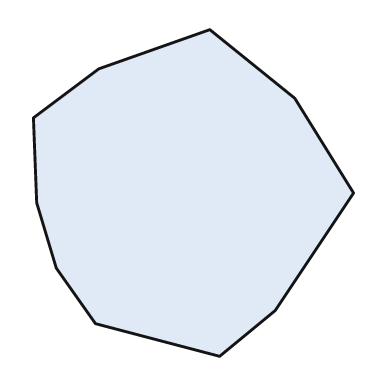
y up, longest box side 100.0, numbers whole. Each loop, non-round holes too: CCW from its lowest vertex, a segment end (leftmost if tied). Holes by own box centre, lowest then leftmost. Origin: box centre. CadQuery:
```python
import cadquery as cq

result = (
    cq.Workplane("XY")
    .moveTo(8.0, -50.0)
    .lineTo(25.0, -36.0)
    .lineTo(49.0, 0.0)
    .lineTo(31.0, 29.0)
    .lineTo(5.0, 50.0)
    .lineTo(-29.0, 38.0)
    .lineTo(-49.0, 23.0)
    .lineTo(-48.0, -3.0)
    .lineTo(-42.0, -23.0)
    .lineTo(-30.0, -40.0)
    .close()
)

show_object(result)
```